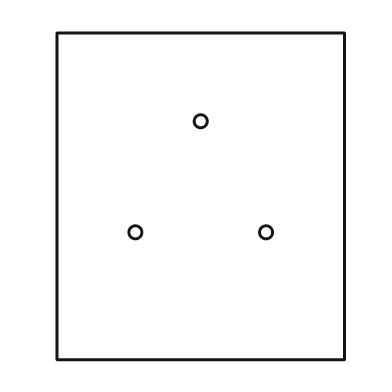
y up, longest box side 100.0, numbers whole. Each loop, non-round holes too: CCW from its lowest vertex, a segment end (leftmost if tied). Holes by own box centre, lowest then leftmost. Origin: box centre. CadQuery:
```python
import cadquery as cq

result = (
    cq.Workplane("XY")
    .moveTo(-44.0, -50.0)
    .lineTo(44.0, -50.0)
    .lineTo(44.0, 50.0)
    .lineTo(-44.0, 50.0)
    .close()
    .moveTo(-20.0, -11.0)
    .circle(2.0)
    .moveTo(20.0, -11.0)
    .circle(2.0)
    .moveTo(0.0, 23.0)
    .circle(2.0)
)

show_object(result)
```